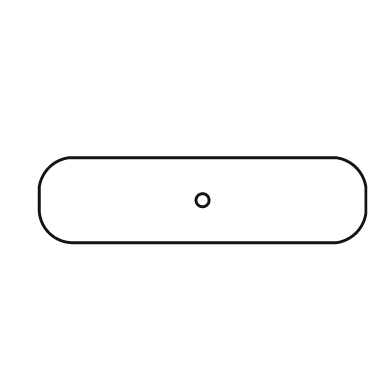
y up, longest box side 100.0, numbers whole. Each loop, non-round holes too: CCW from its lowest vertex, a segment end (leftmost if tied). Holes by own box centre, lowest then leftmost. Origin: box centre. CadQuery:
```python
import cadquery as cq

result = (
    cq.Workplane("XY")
    .moveTo(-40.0, -13.0)
    .lineTo(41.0, -13.0)
    .threePointArc((47.0, -10.0), (50.0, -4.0))
    .lineTo(50.0, 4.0)
    .threePointArc((47.0, 10.0), (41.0, 13.0))
    .lineTo(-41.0, 13.0)
    .threePointArc((-47.0, 10.0), (-50.0, 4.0))
    .lineTo(-50.0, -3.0)
    .threePointArc((-47.0, -10.0), (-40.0, -13.0))
    .close()
    .moveTo(0.0, 0.0)
    .circle(2.0)
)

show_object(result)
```